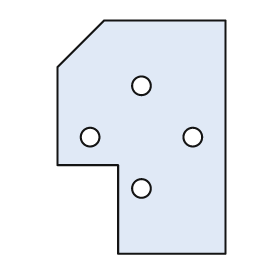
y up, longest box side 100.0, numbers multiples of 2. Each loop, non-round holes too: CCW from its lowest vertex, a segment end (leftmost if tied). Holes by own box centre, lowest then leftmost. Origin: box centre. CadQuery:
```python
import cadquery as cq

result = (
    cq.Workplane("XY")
    .moveTo(-10.0, -50.0)
    .lineTo(36.0, -50.0)
    .lineTo(36.0, 50.0)
    .lineTo(-16.0, 50.0)
    .lineTo(-36.0, 30.0)
    .lineTo(-36.0, -12.0)
    .lineTo(-10.0, -12.0)
    .close()
    .moveTo(0.0, -22.0)
    .circle(4.0)
    .moveTo(-22.0, 0.0)
    .circle(4.0)
    .moveTo(22.0, 0.0)
    .circle(4.0)
    .moveTo(0.0, 22.0)
    .circle(4.0)
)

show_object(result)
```